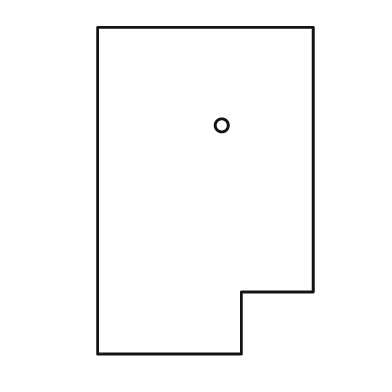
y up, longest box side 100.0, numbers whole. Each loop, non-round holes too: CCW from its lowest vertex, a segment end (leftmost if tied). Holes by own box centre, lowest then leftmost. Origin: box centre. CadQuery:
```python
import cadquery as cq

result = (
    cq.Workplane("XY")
    .moveTo(-33.0, -50.0)
    .lineTo(11.0, -50.0)
    .lineTo(11.0, -31.0)
    .lineTo(33.0, -31.0)
    .lineTo(33.0, 50.0)
    .lineTo(-33.0, 50.0)
    .close()
    .moveTo(5.0, 20.0)
    .circle(2.0)
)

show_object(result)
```